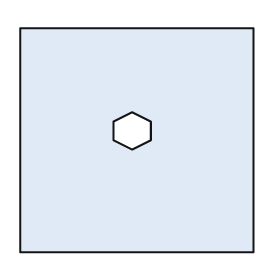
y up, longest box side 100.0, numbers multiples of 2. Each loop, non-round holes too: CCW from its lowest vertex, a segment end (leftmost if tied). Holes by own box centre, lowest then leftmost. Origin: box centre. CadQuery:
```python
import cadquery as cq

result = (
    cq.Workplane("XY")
    .moveTo(-50.0, -48.0)
    .lineTo(50.0, -48.0)
    .lineTo(50.0, 48.0)
    .lineTo(-50.0, 48.0)
    .close()
    .moveTo(-2.0, -4.0)
    .lineTo(6.0, 0.0)
    .lineTo(6.0, 8.0)
    .lineTo(-2.0, 12.0)
    .lineTo(-10.0, 8.0)
    .lineTo(-10.0, 0.0)
    .close()
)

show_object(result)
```